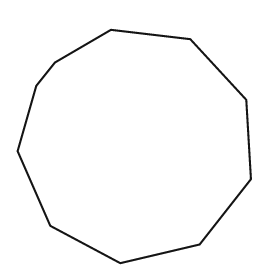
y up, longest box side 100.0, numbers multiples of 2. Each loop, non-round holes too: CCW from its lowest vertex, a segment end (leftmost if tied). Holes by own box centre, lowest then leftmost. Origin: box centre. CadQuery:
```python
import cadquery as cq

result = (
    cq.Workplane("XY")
    .moveTo(-6.0, -50.0)
    .lineTo(28.0, -42.0)
    .lineTo(50.0, -14.0)
    .lineTo(48.0, 20.0)
    .lineTo(24.0, 46.0)
    .lineTo(-10.0, 50.0)
    .lineTo(-34.0, 36.0)
    .lineTo(-42.0, 26.0)
    .lineTo(-50.0, -2.0)
    .lineTo(-36.0, -34.0)
    .close()
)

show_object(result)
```